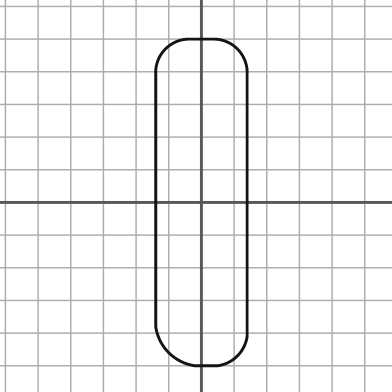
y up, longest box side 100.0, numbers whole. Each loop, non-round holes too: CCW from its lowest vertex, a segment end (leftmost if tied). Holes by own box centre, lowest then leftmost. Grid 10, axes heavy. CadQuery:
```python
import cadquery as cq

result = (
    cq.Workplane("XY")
    .moveTo(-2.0, -50.0)
    .lineTo(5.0, -50.0)
    .threePointArc((11.0, -47.0), (14.0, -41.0))
    .lineTo(14.0, 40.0)
    .threePointArc((11.0, 47.0), (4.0, 50.0))
    .lineTo(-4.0, 50.0)
    .threePointArc((-11.0, 47.0), (-14.0, 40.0))
    .lineTo(-14.0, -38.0)
    .threePointArc((-10.0, -46.0), (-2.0, -50.0))
    .close()
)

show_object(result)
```